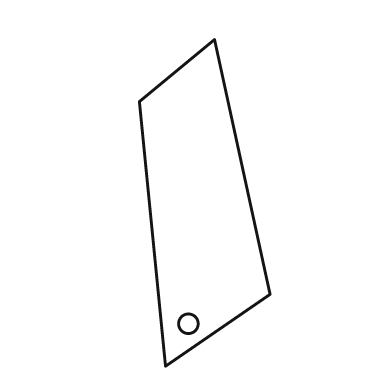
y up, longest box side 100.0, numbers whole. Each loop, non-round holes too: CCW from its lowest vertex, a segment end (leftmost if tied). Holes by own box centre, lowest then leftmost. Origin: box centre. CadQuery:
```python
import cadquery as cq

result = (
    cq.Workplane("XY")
    .moveTo(-12.0, -50.0)
    .lineTo(20.0, -28.0)
    .lineTo(3.0, 50.0)
    .lineTo(-20.0, 31.0)
    .close()
    .moveTo(-5.0, -37.0)
    .circle(3.0)
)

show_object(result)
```